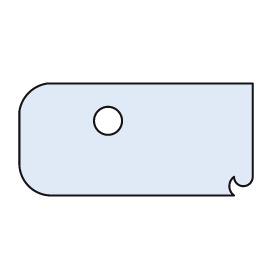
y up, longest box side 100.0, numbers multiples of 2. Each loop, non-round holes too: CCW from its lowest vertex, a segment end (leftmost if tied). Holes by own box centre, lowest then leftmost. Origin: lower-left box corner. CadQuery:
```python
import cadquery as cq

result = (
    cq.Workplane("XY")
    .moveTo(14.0, 0.0)
    .lineTo(92.0, 0.0)
    .threePointArc((90.0, 4.0), (92.0, 8.0))
    .threePointArc((96.0, 4.0), (100.0, 8.0))
    .lineTo(100.0, 48.0)
    .lineTo(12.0, 48.0)
    .threePointArc((4.0, 44.0), (0.0, 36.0))
    .lineTo(0.0, 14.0)
    .threePointArc((4.0, 4.0), (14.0, 0.0))
    .close()
    .moveTo(38.0, 32.0)
    .circle(6.0)
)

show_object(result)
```